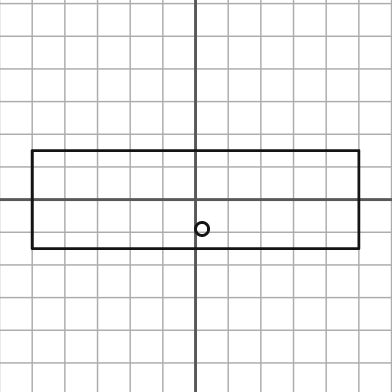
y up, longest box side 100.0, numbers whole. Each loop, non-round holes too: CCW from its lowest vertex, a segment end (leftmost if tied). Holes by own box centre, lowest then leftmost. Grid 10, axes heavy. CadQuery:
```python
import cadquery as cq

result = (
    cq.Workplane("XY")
    .moveTo(-50.0, -15.0)
    .lineTo(50.0, -15.0)
    .lineTo(50.0, 15.0)
    .lineTo(-50.0, 15.0)
    .close()
    .moveTo(2.0, -9.0)
    .circle(2.0)
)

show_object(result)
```